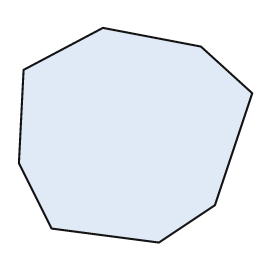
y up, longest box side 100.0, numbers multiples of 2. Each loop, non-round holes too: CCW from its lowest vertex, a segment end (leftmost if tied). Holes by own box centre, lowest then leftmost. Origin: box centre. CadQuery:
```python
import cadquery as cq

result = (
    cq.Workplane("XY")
    .moveTo(10.0, -46.0)
    .lineTo(34.0, -30.0)
    .lineTo(50.0, 18.0)
    .lineTo(28.0, 38.0)
    .lineTo(-14.0, 46.0)
    .lineTo(-48.0, 28.0)
    .lineTo(-50.0, -12.0)
    .lineTo(-36.0, -40.0)
    .close()
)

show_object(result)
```